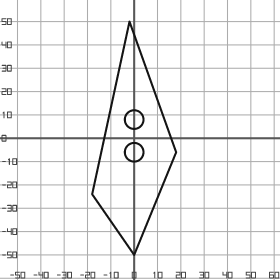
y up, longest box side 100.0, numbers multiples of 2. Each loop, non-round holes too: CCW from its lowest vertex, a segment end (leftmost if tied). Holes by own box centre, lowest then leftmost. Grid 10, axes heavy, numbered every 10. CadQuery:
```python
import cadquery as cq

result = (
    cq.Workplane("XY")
    .moveTo(0.0, -50.0)
    .lineTo(18.0, -6.0)
    .lineTo(-2.0, 50.0)
    .lineTo(-18.0, -24.0)
    .close()
    .moveTo(0.0, -6.0)
    .circle(4.0)
    .moveTo(0.0, 8.0)
    .circle(4.0)
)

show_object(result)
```